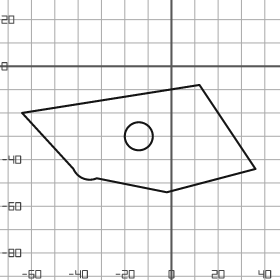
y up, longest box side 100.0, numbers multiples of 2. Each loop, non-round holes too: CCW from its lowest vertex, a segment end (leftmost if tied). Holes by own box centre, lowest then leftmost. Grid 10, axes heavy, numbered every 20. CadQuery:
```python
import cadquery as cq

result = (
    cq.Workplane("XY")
    .moveTo(-2.0, -54.0)
    .lineTo(36.0, -44.0)
    .lineTo(12.0, -8.0)
    .lineTo(-64.0, -20.0)
    .lineTo(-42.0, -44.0)
    .threePointArc((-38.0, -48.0), (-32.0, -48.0))
    .close()
    .moveTo(-14.0, -30.0)
    .circle(6.0)
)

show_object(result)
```